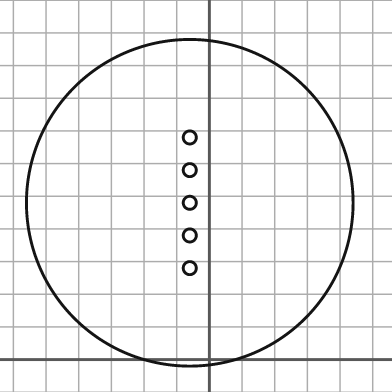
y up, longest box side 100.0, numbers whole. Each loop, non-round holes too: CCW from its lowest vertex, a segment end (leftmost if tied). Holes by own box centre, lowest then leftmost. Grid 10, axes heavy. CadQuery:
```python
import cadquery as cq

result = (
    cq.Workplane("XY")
    .moveTo(-6.0, 48.0)
    .circle(50.0)
    .moveTo(-6.0, 28.0)
    .circle(2.0)
    .moveTo(-6.0, 38.0)
    .circle(2.0)
    .moveTo(-6.0, 48.0)
    .circle(2.0)
    .moveTo(-6.0, 58.0)
    .circle(2.0)
    .moveTo(-6.0, 68.0)
    .circle(2.0)
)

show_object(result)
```